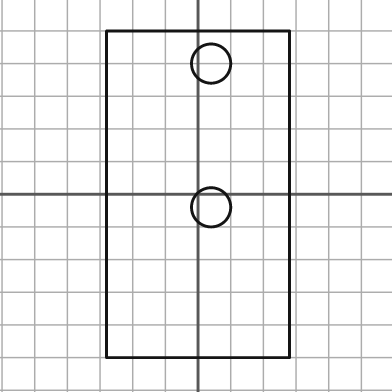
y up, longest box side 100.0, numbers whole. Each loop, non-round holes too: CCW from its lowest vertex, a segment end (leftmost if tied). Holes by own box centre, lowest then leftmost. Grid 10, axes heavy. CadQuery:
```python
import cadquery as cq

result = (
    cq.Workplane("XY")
    .moveTo(-28.0, -50.0)
    .lineTo(28.0, -50.0)
    .lineTo(28.0, 50.0)
    .lineTo(-28.0, 50.0)
    .close()
    .moveTo(4.0, -4.0)
    .circle(6.0)
    .moveTo(4.0, 40.0)
    .circle(6.0)
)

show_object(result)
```